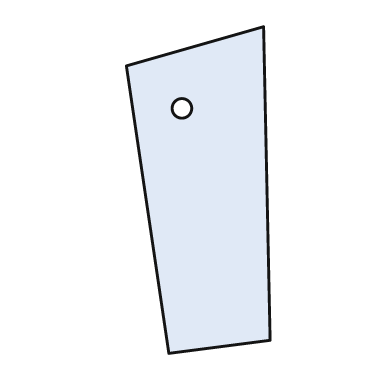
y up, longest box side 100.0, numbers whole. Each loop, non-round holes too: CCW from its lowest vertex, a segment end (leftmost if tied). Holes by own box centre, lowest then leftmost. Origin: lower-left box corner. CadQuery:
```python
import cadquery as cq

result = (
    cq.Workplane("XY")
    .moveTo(13.0, 0.0)
    .lineTo(44.0, 4.0)
    .lineTo(42.0, 100.0)
    .lineTo(0.0, 88.0)
    .close()
    .moveTo(17.0, 75.0)
    .circle(3.0)
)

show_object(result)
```